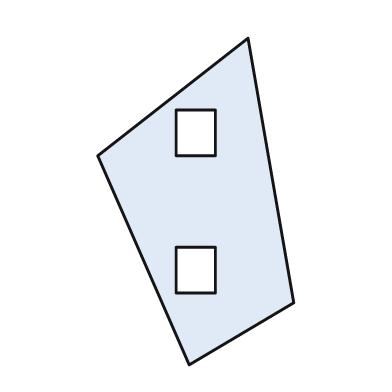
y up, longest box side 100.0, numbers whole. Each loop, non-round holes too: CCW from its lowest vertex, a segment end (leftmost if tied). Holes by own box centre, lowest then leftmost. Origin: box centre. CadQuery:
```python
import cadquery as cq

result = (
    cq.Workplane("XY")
    .moveTo(-2.0, -50.0)
    .lineTo(30.0, -31.0)
    .lineTo(16.0, 50.0)
    .lineTo(-30.0, 14.0)
    .close()
    .moveTo(-6.0, -28.0)
    .lineTo(6.0, -28.0)
    .lineTo(6.0, -14.0)
    .lineTo(-6.0, -14.0)
    .close()
    .moveTo(-6.0, 14.0)
    .lineTo(6.0, 14.0)
    .lineTo(6.0, 28.0)
    .lineTo(-6.0, 28.0)
    .close()
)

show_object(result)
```